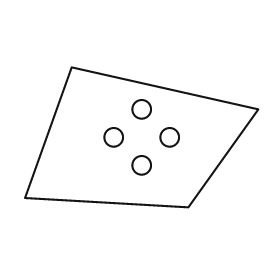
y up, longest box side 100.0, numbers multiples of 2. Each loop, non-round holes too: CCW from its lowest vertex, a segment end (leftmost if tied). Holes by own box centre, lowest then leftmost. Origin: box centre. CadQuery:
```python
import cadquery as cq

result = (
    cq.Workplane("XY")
    .moveTo(20.0, -30.0)
    .lineTo(50.0, 12.0)
    .lineTo(-30.0, 30.0)
    .lineTo(-50.0, -26.0)
    .close()
    .moveTo(0.0, -12.0)
    .circle(4.0)
    .moveTo(-12.0, 0.0)
    .circle(4.0)
    .moveTo(12.0, 0.0)
    .circle(4.0)
    .moveTo(0.0, 12.0)
    .circle(4.0)
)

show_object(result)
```